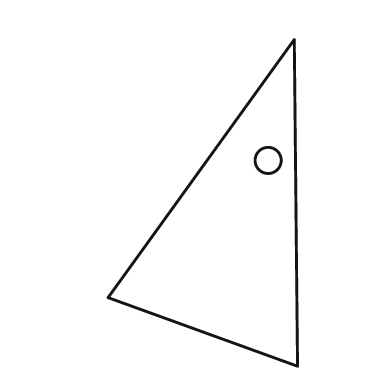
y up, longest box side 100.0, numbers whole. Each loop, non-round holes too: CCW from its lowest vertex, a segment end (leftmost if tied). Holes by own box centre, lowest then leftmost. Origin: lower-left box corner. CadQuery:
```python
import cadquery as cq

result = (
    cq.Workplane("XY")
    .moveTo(58.0, 0.0)
    .lineTo(57.0, 100.0)
    .lineTo(0.0, 21.0)
    .close()
    .moveTo(49.0, 63.0)
    .circle(4.0)
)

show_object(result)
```